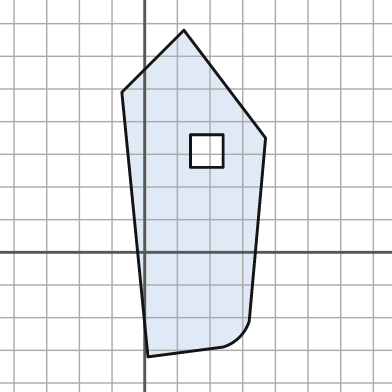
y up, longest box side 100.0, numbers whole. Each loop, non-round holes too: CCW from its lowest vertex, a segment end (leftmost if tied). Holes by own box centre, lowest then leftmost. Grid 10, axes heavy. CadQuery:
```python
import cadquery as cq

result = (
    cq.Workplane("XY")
    .moveTo(1.0, -32.0)
    .lineTo(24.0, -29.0)
    .threePointArc((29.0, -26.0), (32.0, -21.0))
    .lineTo(37.0, 35.0)
    .lineTo(12.0, 68.0)
    .lineTo(-7.0, 49.0)
    .close()
    .moveTo(14.0, 26.0)
    .lineTo(24.0, 26.0)
    .lineTo(24.0, 36.0)
    .lineTo(14.0, 36.0)
    .close()
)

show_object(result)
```